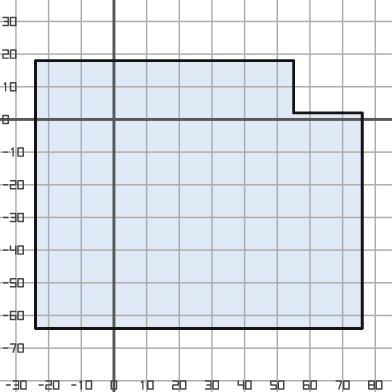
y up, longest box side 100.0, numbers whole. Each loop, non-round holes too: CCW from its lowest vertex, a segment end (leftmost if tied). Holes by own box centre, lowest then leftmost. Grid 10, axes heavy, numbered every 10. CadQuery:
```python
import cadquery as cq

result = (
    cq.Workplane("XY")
    .moveTo(-24.0, -64.0)
    .lineTo(76.0, -64.0)
    .lineTo(76.0, 2.0)
    .lineTo(55.0, 2.0)
    .lineTo(55.0, 18.0)
    .lineTo(-24.0, 18.0)
    .close()
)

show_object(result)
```